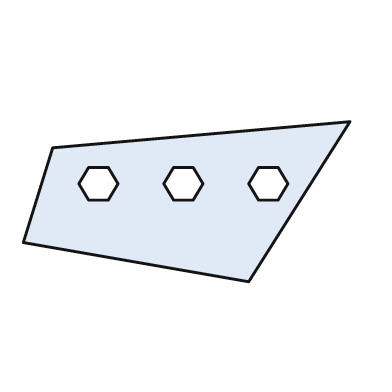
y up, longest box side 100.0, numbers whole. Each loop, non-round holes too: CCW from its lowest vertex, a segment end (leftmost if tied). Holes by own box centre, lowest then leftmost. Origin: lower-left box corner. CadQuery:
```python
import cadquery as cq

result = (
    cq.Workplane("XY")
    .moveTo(69.0, 0.0)
    .lineTo(100.0, 49.0)
    .lineTo(9.0, 41.0)
    .lineTo(0.0, 12.0)
    .close()
    .moveTo(20.0, 25.0)
    .lineTo(26.0, 25.0)
    .lineTo(29.0, 30.0)
    .lineTo(26.0, 35.0)
    .lineTo(20.0, 35.0)
    .lineTo(17.0, 30.0)
    .close()
    .moveTo(46.0, 25.0)
    .lineTo(52.0, 25.0)
    .lineTo(55.0, 30.0)
    .lineTo(52.0, 35.0)
    .lineTo(46.0, 35.0)
    .lineTo(43.0, 30.0)
    .close()
    .moveTo(72.0, 25.0)
    .lineTo(78.0, 25.0)
    .lineTo(81.0, 30.0)
    .lineTo(78.0, 35.0)
    .lineTo(72.0, 35.0)
    .lineTo(69.0, 30.0)
    .close()
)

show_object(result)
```